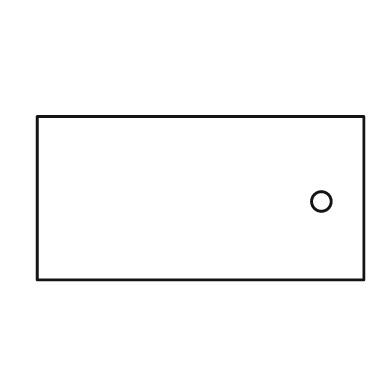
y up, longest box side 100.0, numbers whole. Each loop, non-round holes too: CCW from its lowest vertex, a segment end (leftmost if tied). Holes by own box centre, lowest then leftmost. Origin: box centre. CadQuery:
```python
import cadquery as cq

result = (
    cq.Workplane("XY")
    .moveTo(-50.0, -25.0)
    .lineTo(50.0, -25.0)
    .lineTo(50.0, 25.0)
    .lineTo(-50.0, 25.0)
    .close()
    .moveTo(37.0, -1.0)
    .circle(3.0)
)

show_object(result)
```